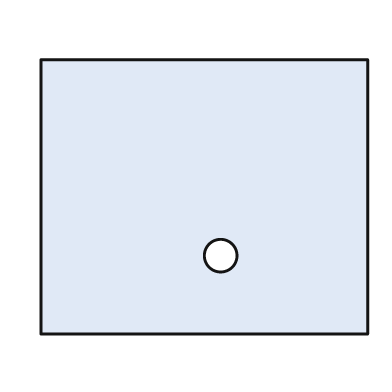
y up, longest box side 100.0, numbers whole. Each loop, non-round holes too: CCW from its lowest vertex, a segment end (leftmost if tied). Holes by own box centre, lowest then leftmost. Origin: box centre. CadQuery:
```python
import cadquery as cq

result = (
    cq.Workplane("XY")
    .moveTo(-50.0, -42.0)
    .lineTo(50.0, -42.0)
    .lineTo(50.0, 42.0)
    .lineTo(-50.0, 42.0)
    .close()
    .moveTo(5.0, -18.0)
    .circle(5.0)
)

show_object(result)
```